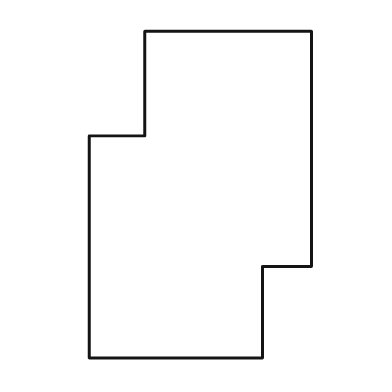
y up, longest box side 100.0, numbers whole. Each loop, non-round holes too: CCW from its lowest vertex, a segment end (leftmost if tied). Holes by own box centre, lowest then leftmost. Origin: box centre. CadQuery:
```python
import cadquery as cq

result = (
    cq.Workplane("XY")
    .moveTo(-34.0, -50.0)
    .lineTo(19.0, -50.0)
    .lineTo(19.0, -22.0)
    .lineTo(34.0, -22.0)
    .lineTo(34.0, 50.0)
    .lineTo(-17.0, 50.0)
    .lineTo(-17.0, 18.0)
    .lineTo(-34.0, 18.0)
    .close()
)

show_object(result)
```